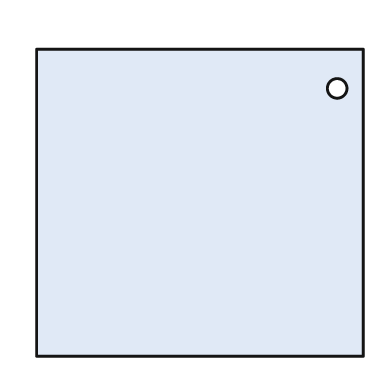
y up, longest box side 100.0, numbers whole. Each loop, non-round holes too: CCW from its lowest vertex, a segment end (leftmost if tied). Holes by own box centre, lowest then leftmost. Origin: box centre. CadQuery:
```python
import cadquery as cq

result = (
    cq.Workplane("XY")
    .moveTo(-50.0, -47.0)
    .lineTo(50.0, -47.0)
    .lineTo(50.0, 47.0)
    .lineTo(-50.0, 47.0)
    .close()
    .moveTo(42.0, 35.0)
    .circle(3.0)
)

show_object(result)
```